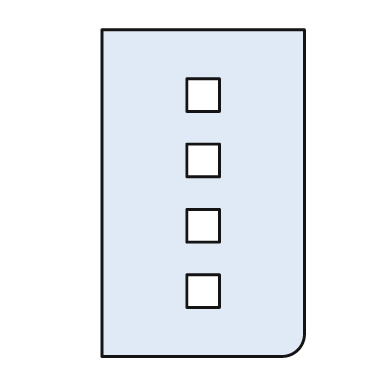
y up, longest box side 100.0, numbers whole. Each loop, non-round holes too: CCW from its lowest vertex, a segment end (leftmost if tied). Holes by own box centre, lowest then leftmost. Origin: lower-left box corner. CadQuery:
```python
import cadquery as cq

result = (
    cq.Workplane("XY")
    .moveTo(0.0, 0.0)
    .lineTo(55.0, 0.0)
    .threePointArc((60.0, 2.0), (62.0, 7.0))
    .lineTo(62.0, 100.0)
    .lineTo(0.0, 100.0)
    .close()
    .moveTo(26.0, 15.0)
    .lineTo(36.0, 15.0)
    .lineTo(36.0, 25.0)
    .lineTo(26.0, 25.0)
    .close()
    .moveTo(26.0, 35.0)
    .lineTo(36.0, 35.0)
    .lineTo(36.0, 45.0)
    .lineTo(26.0, 45.0)
    .close()
    .moveTo(26.0, 55.0)
    .lineTo(36.0, 55.0)
    .lineTo(36.0, 65.0)
    .lineTo(26.0, 65.0)
    .close()
    .moveTo(26.0, 75.0)
    .lineTo(36.0, 75.0)
    .lineTo(36.0, 85.0)
    .lineTo(26.0, 85.0)
    .close()
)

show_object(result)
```